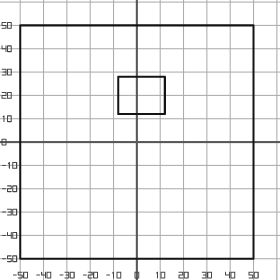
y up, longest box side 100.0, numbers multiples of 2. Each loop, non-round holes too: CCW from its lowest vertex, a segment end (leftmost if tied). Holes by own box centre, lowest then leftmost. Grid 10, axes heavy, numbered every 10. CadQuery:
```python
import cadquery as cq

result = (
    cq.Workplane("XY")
    .moveTo(-50.0, -50.0)
    .lineTo(50.0, -50.0)
    .lineTo(50.0, 50.0)
    .lineTo(-50.0, 50.0)
    .close()
    .moveTo(-8.0, 12.0)
    .lineTo(12.0, 12.0)
    .lineTo(12.0, 28.0)
    .lineTo(-8.0, 28.0)
    .close()
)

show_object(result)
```